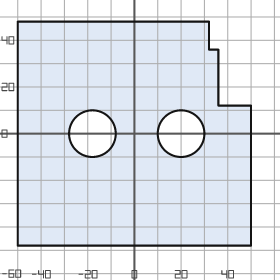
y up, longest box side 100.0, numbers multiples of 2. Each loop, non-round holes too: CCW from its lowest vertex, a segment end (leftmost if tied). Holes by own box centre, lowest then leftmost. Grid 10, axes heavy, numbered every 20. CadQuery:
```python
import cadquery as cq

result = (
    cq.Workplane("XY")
    .moveTo(-50.0, -48.0)
    .lineTo(50.0, -48.0)
    .lineTo(50.0, 12.0)
    .lineTo(36.0, 12.0)
    .lineTo(36.0, 36.0)
    .lineTo(32.0, 36.0)
    .lineTo(32.0, 48.0)
    .lineTo(-50.0, 48.0)
    .close()
    .moveTo(-18.0, 0.0)
    .circle(10.0)
    .moveTo(20.0, 0.0)
    .circle(10.0)
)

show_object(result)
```